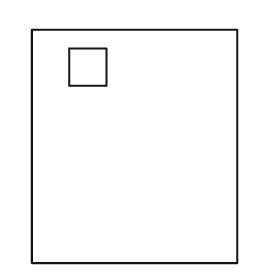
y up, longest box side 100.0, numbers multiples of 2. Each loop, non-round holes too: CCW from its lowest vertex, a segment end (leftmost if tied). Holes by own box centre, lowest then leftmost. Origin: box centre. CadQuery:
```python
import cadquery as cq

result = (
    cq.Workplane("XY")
    .moveTo(-44.0, -50.0)
    .lineTo(44.0, -50.0)
    .lineTo(44.0, 50.0)
    .lineTo(-44.0, 50.0)
    .close()
    .moveTo(-28.0, 26.0)
    .lineTo(-12.0, 26.0)
    .lineTo(-12.0, 42.0)
    .lineTo(-28.0, 42.0)
    .close()
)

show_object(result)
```